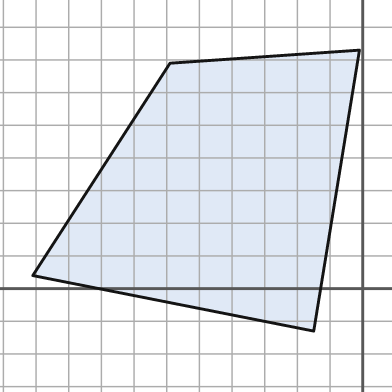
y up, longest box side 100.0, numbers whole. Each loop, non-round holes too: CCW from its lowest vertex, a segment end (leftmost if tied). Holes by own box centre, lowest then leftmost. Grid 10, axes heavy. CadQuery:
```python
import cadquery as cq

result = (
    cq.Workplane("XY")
    .moveTo(-15.0, -13.0)
    .lineTo(-1.0, 73.0)
    .lineTo(-59.0, 69.0)
    .lineTo(-101.0, 4.0)
    .close()
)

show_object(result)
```